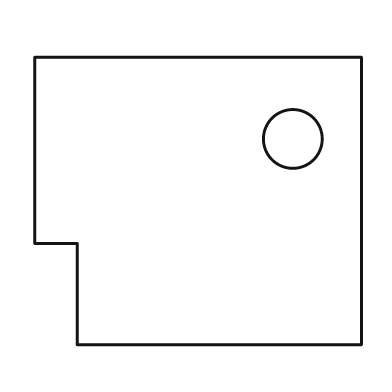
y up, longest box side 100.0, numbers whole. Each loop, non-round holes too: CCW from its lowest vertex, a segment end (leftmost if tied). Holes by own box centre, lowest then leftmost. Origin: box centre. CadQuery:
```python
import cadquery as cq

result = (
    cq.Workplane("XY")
    .moveTo(-37.0, -44.0)
    .lineTo(50.0, -44.0)
    .lineTo(50.0, 44.0)
    .lineTo(-50.0, 44.0)
    .lineTo(-50.0, -13.0)
    .lineTo(-37.0, -13.0)
    .close()
    .moveTo(29.0, 19.0)
    .circle(9.0)
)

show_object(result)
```